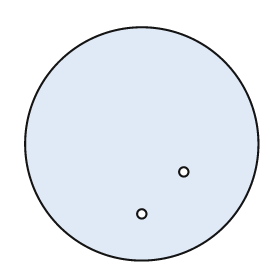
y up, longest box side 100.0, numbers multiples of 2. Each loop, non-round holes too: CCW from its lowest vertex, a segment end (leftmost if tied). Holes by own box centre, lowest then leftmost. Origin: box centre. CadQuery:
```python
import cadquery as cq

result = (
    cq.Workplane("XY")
    .moveTo(0.0, 0.0)
    .circle(50.0)
    .moveTo(0.0, -30.0)
    .circle(2.0)
    .moveTo(18.0, -12.0)
    .circle(2.0)
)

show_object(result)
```